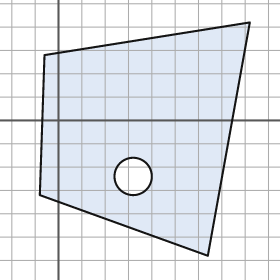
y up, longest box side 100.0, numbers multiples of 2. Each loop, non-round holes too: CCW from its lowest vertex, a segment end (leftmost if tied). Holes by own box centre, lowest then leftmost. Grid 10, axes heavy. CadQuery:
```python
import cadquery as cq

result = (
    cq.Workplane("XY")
    .moveTo(64.0, -58.0)
    .lineTo(82.0, 42.0)
    .lineTo(-6.0, 28.0)
    .lineTo(-8.0, -32.0)
    .close()
    .moveTo(32.0, -24.0)
    .circle(8.0)
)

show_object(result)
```